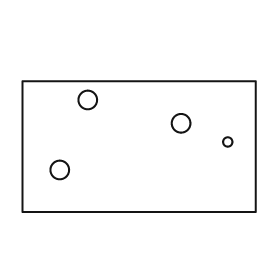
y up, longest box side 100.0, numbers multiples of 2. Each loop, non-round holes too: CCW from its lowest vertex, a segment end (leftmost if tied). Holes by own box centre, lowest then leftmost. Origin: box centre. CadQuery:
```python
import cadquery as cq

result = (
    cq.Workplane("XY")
    .moveTo(-50.0, -28.0)
    .lineTo(50.0, -28.0)
    .lineTo(50.0, 28.0)
    .lineTo(-50.0, 28.0)
    .close()
    .moveTo(-34.0, -10.0)
    .circle(4.0)
    .moveTo(38.0, 2.0)
    .circle(2.0)
    .moveTo(18.0, 10.0)
    .circle(4.0)
    .moveTo(-22.0, 20.0)
    .circle(4.0)
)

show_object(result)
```